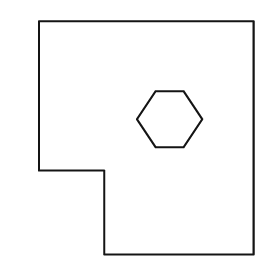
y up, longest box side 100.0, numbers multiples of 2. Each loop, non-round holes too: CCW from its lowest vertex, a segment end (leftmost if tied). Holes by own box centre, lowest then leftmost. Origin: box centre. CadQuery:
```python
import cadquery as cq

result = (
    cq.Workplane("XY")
    .moveTo(-18.0, -50.0)
    .lineTo(46.0, -50.0)
    .lineTo(46.0, 50.0)
    .lineTo(-46.0, 50.0)
    .lineTo(-46.0, -14.0)
    .lineTo(-18.0, -14.0)
    .close()
    .moveTo(4.0, -4.0)
    .lineTo(16.0, -4.0)
    .lineTo(24.0, 8.0)
    .lineTo(16.0, 20.0)
    .lineTo(4.0, 20.0)
    .lineTo(-4.0, 8.0)
    .close()
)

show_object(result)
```